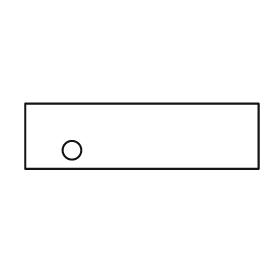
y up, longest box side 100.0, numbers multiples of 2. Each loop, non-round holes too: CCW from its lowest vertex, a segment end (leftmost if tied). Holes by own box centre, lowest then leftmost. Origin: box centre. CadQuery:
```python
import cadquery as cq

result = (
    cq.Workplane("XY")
    .moveTo(-50.0, -14.0)
    .lineTo(50.0, -14.0)
    .lineTo(50.0, 14.0)
    .lineTo(-50.0, 14.0)
    .close()
    .moveTo(-30.0, -6.0)
    .circle(4.0)
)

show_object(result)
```